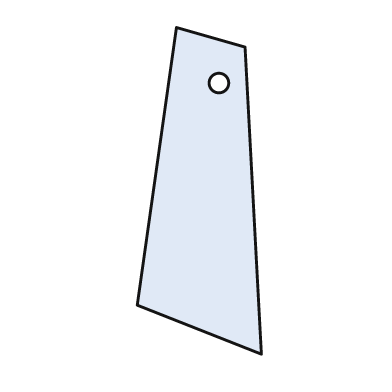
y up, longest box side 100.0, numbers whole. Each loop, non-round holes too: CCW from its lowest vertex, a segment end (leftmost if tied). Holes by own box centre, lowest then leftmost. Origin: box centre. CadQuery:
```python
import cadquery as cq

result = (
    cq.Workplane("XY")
    .moveTo(19.0, -50.0)
    .lineTo(14.0, 44.0)
    .lineTo(-7.0, 50.0)
    .lineTo(-19.0, -35.0)
    .close()
    .moveTo(6.0, 33.0)
    .circle(3.0)
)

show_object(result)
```